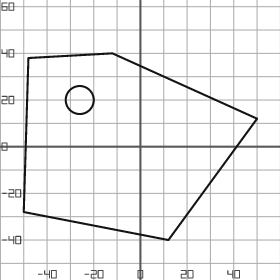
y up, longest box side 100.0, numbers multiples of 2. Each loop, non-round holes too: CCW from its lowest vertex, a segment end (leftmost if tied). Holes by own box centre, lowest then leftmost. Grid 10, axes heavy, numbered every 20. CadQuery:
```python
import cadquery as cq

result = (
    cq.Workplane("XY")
    .moveTo(12.0, -40.0)
    .lineTo(50.0, 12.0)
    .lineTo(-12.0, 40.0)
    .lineTo(-48.0, 38.0)
    .lineTo(-50.0, -28.0)
    .close()
    .moveTo(-26.0, 20.0)
    .circle(6.0)
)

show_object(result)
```